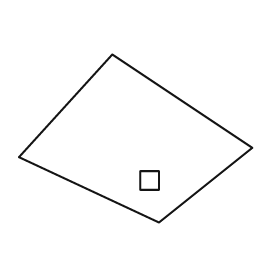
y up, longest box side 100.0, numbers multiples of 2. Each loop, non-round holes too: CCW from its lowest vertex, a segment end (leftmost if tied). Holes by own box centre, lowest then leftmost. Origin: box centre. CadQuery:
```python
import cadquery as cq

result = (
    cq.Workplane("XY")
    .moveTo(10.0, -36.0)
    .lineTo(50.0, -4.0)
    .lineTo(-10.0, 36.0)
    .lineTo(-50.0, -8.0)
    .close()
    .moveTo(2.0, -22.0)
    .lineTo(10.0, -22.0)
    .lineTo(10.0, -14.0)
    .lineTo(2.0, -14.0)
    .close()
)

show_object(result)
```